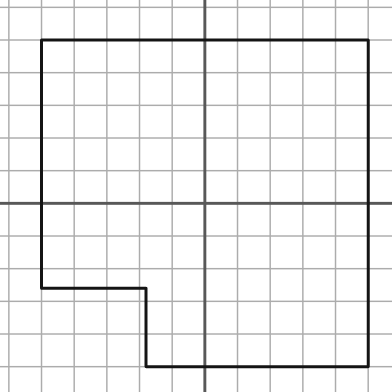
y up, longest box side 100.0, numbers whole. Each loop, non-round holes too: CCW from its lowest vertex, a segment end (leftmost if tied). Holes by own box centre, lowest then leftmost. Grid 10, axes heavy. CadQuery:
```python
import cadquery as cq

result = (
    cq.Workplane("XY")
    .moveTo(-18.0, -50.0)
    .lineTo(50.0, -50.0)
    .lineTo(50.0, 50.0)
    .lineTo(-50.0, 50.0)
    .lineTo(-50.0, -26.0)
    .lineTo(-18.0, -26.0)
    .close()
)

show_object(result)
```